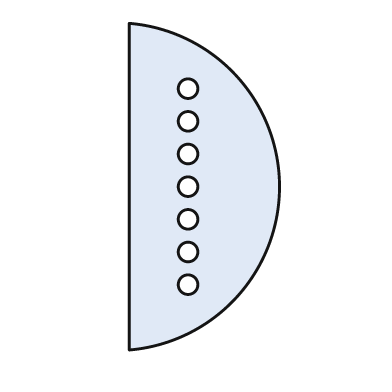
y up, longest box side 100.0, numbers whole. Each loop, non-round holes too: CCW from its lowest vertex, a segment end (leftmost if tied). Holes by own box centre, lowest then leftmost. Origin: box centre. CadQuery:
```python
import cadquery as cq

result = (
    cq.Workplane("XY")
    .moveTo(-23.0, -50.0)
    .threePointArc((23.0, 0.0), (-23.0, 50.0))
    .close()
    .moveTo(-5.0, -30.0)
    .circle(3.0)
    .moveTo(-5.0, -20.0)
    .circle(3.0)
    .moveTo(-5.0, -10.0)
    .circle(3.0)
    .moveTo(-5.0, 0.0)
    .circle(3.0)
    .moveTo(-5.0, 10.0)
    .circle(3.0)
    .moveTo(-5.0, 20.0)
    .circle(3.0)
    .moveTo(-5.0, 30.0)
    .circle(3.0)
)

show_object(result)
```